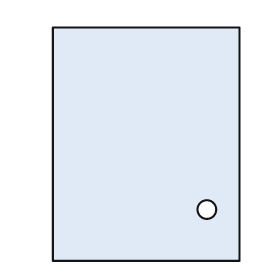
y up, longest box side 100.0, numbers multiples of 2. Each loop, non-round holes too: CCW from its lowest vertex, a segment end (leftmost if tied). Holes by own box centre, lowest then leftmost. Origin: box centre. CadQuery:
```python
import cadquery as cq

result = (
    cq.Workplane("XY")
    .moveTo(-40.0, -50.0)
    .lineTo(40.0, -50.0)
    .lineTo(40.0, 50.0)
    .lineTo(-40.0, 50.0)
    .close()
    .moveTo(26.0, -28.0)
    .circle(4.0)
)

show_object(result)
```